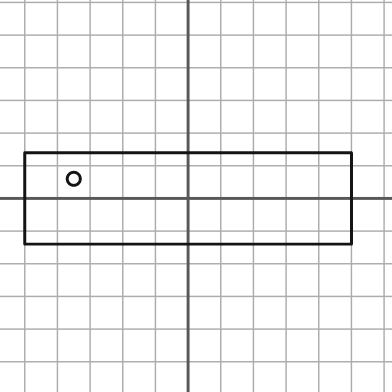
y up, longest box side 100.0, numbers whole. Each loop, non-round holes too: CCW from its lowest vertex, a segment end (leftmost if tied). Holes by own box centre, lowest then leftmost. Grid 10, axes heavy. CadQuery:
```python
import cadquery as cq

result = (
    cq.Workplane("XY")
    .moveTo(-50.0, -14.0)
    .lineTo(50.0, -14.0)
    .lineTo(50.0, 14.0)
    .lineTo(-50.0, 14.0)
    .close()
    .moveTo(-35.0, 6.0)
    .circle(2.0)
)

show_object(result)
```